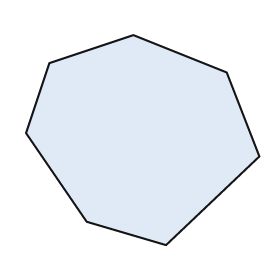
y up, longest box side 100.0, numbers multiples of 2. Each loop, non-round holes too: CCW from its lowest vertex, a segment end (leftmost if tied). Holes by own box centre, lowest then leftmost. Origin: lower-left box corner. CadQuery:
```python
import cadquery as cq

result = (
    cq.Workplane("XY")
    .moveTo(60.0, 0.0)
    .lineTo(100.0, 38.0)
    .lineTo(86.0, 74.0)
    .lineTo(46.0, 90.0)
    .lineTo(10.0, 78.0)
    .lineTo(0.0, 48.0)
    .lineTo(26.0, 10.0)
    .close()
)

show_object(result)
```